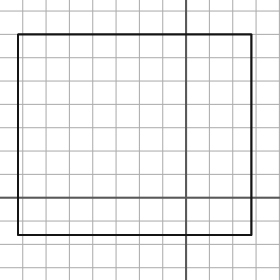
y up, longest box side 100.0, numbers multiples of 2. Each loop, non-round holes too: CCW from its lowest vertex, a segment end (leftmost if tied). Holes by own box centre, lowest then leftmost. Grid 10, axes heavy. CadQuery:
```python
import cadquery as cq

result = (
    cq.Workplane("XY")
    .moveTo(-72.0, -16.0)
    .lineTo(28.0, -16.0)
    .lineTo(28.0, 70.0)
    .lineTo(-72.0, 70.0)
    .close()
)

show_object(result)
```